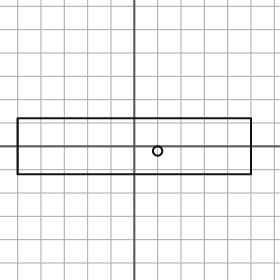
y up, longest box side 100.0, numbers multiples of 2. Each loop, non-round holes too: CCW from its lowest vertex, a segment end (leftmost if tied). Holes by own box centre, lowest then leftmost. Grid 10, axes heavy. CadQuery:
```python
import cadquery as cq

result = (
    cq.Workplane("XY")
    .moveTo(-50.0, -12.0)
    .lineTo(50.0, -12.0)
    .lineTo(50.0, 12.0)
    .lineTo(-50.0, 12.0)
    .close()
    .moveTo(10.0, -2.0)
    .circle(2.0)
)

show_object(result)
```